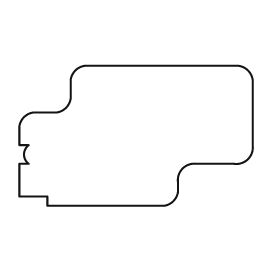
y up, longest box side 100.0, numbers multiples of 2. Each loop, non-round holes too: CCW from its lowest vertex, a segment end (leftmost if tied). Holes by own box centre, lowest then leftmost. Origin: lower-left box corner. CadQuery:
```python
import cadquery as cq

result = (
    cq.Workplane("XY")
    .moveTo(12.0, 0.0)
    .lineTo(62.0, 0.0)
    .threePointArc((66.0, 2.0), (68.0, 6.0))
    .lineTo(68.0, 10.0)
    .threePointArc((70.0, 16.0), (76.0, 18.0))
    .lineTo(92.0, 18.0)
    .threePointArc((98.0, 20.0), (100.0, 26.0))
    .lineTo(100.0, 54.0)
    .threePointArc((98.0, 58.0), (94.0, 60.0))
    .lineTo(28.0, 60.0)
    .threePointArc((24.0, 58.0), (22.0, 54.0))
    .lineTo(22.0, 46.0)
    .threePointArc((20.0, 42.0), (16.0, 40.0))
    .lineTo(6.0, 40.0)
    .threePointArc((2.0, 38.0), (0.0, 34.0))
    .lineTo(0.0, 26.0)
    .lineTo(4.0, 26.0)
    .threePointArc((2.0, 22.0), (4.0, 18.0))
    .lineTo(0.0, 18.0)
    .lineTo(0.0, 4.0)
    .lineTo(12.0, 4.0)
    .close()
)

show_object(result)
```